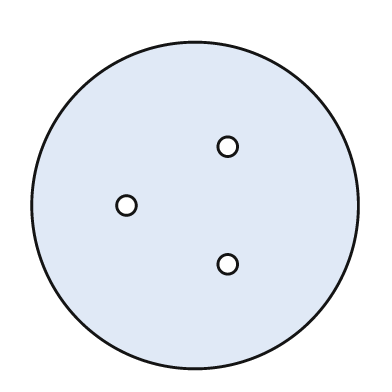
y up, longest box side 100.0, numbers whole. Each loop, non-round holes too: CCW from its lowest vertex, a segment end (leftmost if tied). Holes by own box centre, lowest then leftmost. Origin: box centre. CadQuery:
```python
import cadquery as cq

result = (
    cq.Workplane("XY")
    .moveTo(0.0, 0.0)
    .circle(50.0)
    .moveTo(10.0, -18.0)
    .circle(3.0)
    .moveTo(-21.0, 0.0)
    .circle(3.0)
    .moveTo(10.0, 18.0)
    .circle(3.0)
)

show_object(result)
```